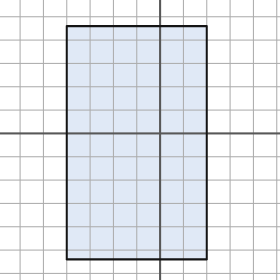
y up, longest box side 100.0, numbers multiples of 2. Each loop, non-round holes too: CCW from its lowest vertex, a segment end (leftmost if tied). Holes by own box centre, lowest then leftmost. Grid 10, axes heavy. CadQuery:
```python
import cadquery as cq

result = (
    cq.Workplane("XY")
    .moveTo(-40.0, -54.0)
    .lineTo(20.0, -54.0)
    .lineTo(20.0, 46.0)
    .lineTo(-40.0, 46.0)
    .close()
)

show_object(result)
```